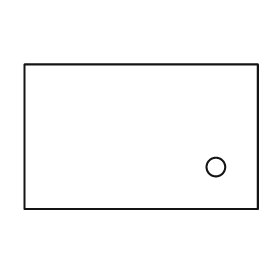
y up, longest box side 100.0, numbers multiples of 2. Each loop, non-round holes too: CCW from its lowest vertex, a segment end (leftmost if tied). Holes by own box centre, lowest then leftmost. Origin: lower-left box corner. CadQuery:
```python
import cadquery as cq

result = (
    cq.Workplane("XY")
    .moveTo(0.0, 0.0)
    .lineTo(100.0, 0.0)
    .lineTo(100.0, 62.0)
    .lineTo(0.0, 62.0)
    .close()
    .moveTo(82.0, 18.0)
    .circle(4.0)
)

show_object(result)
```